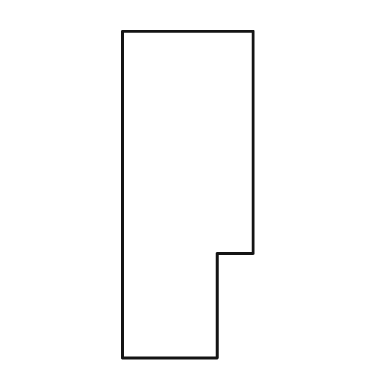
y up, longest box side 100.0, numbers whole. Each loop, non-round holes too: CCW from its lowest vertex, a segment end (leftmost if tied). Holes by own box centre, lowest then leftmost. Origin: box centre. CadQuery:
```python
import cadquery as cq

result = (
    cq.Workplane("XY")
    .moveTo(-20.0, -50.0)
    .lineTo(9.0, -50.0)
    .lineTo(9.0, -18.0)
    .lineTo(20.0, -18.0)
    .lineTo(20.0, 50.0)
    .lineTo(-20.0, 50.0)
    .close()
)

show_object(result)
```